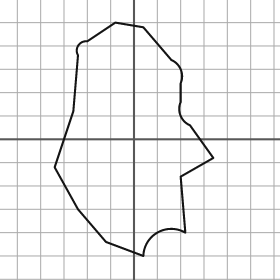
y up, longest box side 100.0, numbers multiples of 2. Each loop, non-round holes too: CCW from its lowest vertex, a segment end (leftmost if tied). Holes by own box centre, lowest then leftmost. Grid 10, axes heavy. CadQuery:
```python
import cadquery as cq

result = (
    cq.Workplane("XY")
    .moveTo(4.0, -50.0)
    .threePointArc((10.0, -40.0), (22.0, -40.0))
    .lineTo(20.0, -16.0)
    .lineTo(34.0, -8.0)
    .lineTo(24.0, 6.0)
    .threePointArc((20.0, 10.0), (20.0, 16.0))
    .lineTo(20.0, 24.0)
    .threePointArc((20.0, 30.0), (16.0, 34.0))
    .lineTo(4.0, 48.0)
    .lineTo(-8.0, 50.0)
    .lineTo(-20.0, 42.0)
    .threePointArc((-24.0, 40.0), (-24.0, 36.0))
    .lineTo(-26.0, 12.0)
    .lineTo(-34.0, -12.0)
    .lineTo(-24.0, -30.0)
    .lineTo(-12.0, -44.0)
    .close()
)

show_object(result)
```